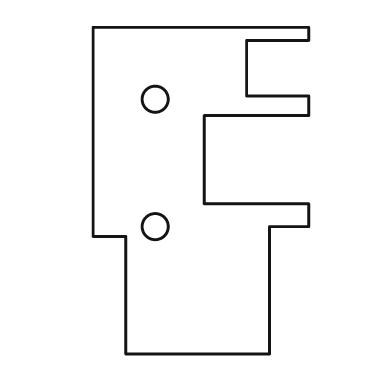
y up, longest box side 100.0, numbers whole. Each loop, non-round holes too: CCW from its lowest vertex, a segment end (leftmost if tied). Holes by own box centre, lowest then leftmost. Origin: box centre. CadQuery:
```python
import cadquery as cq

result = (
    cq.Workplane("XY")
    .moveTo(-23.0, -50.0)
    .lineTo(21.0, -50.0)
    .lineTo(21.0, -11.0)
    .lineTo(33.0, -11.0)
    .lineTo(33.0, -4.0)
    .lineTo(1.0, -4.0)
    .lineTo(1.0, 23.0)
    .lineTo(33.0, 23.0)
    .lineTo(33.0, 29.0)
    .lineTo(14.0, 29.0)
    .lineTo(14.0, 46.0)
    .lineTo(33.0, 46.0)
    .lineTo(33.0, 50.0)
    .lineTo(-33.0, 50.0)
    .lineTo(-33.0, -14.0)
    .lineTo(-23.0, -14.0)
    .close()
    .moveTo(-14.0, -11.0)
    .circle(4.0)
    .moveTo(-14.0, 28.0)
    .circle(4.0)
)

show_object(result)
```